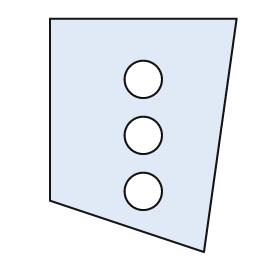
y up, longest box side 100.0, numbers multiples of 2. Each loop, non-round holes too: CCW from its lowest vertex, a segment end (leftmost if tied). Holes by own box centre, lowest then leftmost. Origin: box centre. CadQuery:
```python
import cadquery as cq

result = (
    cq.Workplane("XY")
    .moveTo(26.0, -50.0)
    .lineTo(40.0, 50.0)
    .lineTo(-40.0, 50.0)
    .lineTo(-40.0, -28.0)
    .close()
    .moveTo(0.0, -24.0)
    .circle(8.0)
    .moveTo(0.0, 0.0)
    .circle(8.0)
    .moveTo(0.0, 24.0)
    .circle(8.0)
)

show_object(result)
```